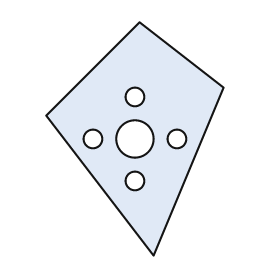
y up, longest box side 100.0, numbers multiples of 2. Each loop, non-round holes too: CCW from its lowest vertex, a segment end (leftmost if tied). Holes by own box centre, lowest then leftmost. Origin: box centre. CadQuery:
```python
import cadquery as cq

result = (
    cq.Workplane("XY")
    .moveTo(8.0, -50.0)
    .lineTo(38.0, 22.0)
    .lineTo(2.0, 50.0)
    .lineTo(-38.0, 10.0)
    .close()
    .moveTo(0.0, -18.0)
    .circle(4.0)
    .moveTo(-18.0, 0.0)
    .circle(4.0)
    .moveTo(0.0, 0.0)
    .circle(8.0)
    .moveTo(18.0, 0.0)
    .circle(4.0)
    .moveTo(0.0, 18.0)
    .circle(4.0)
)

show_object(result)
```